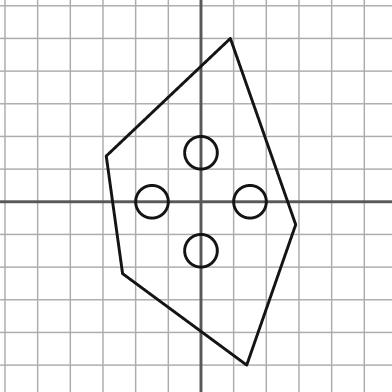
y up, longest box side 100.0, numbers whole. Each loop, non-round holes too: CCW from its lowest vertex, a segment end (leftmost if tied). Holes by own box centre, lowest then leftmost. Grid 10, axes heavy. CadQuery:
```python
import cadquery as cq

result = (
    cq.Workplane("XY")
    .moveTo(14.0, -50.0)
    .lineTo(29.0, -7.0)
    .lineTo(9.0, 50.0)
    .lineTo(-29.0, 14.0)
    .lineTo(-24.0, -22.0)
    .close()
    .moveTo(0.0, -15.0)
    .circle(5.0)
    .moveTo(-15.0, 0.0)
    .circle(5.0)
    .moveTo(15.0, 0.0)
    .circle(5.0)
    .moveTo(0.0, 15.0)
    .circle(5.0)
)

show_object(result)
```